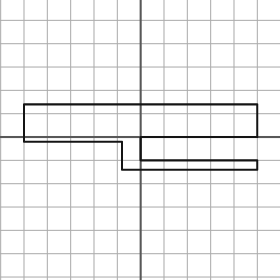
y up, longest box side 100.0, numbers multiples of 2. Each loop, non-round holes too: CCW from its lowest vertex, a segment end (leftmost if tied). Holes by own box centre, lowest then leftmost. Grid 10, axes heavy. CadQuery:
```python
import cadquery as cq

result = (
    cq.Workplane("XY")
    .moveTo(-8.0, -14.0)
    .lineTo(50.0, -14.0)
    .lineTo(50.0, -10.0)
    .lineTo(0.0, -10.0)
    .lineTo(0.0, 0.0)
    .lineTo(50.0, 0.0)
    .lineTo(50.0, 14.0)
    .lineTo(-50.0, 14.0)
    .lineTo(-50.0, -2.0)
    .lineTo(-8.0, -2.0)
    .close()
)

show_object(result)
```